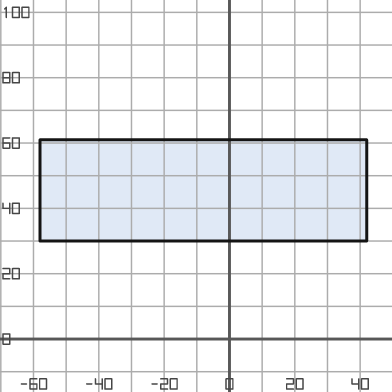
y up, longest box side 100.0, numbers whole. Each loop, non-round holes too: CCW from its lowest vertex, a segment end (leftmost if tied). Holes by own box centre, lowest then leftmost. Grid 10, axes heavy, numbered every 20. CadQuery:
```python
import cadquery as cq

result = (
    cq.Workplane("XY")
    .moveTo(-58.0, 30.0)
    .lineTo(42.0, 30.0)
    .lineTo(42.0, 61.0)
    .lineTo(-58.0, 61.0)
    .close()
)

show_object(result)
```